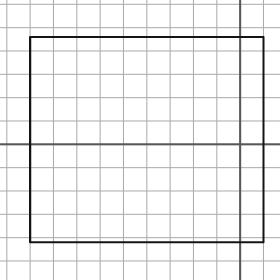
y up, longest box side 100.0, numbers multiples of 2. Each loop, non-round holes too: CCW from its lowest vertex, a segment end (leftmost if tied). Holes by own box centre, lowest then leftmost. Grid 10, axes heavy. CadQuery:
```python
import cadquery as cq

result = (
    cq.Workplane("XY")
    .moveTo(-90.0, -42.0)
    .lineTo(10.0, -42.0)
    .lineTo(10.0, 46.0)
    .lineTo(-90.0, 46.0)
    .close()
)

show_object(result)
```